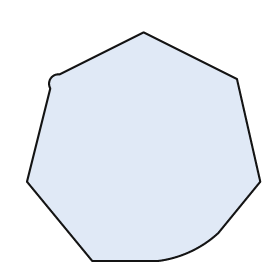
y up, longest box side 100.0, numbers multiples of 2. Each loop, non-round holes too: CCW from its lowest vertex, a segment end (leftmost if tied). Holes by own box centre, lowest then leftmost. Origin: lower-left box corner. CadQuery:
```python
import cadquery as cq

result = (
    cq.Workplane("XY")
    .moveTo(28.0, 0.0)
    .lineTo(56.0, 0.0)
    .threePointArc((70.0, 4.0), (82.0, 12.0))
    .lineTo(100.0, 34.0)
    .lineTo(90.0, 78.0)
    .lineTo(50.0, 98.0)
    .lineTo(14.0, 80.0)
    .threePointArc((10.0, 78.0), (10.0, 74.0))
    .lineTo(0.0, 34.0)
    .close()
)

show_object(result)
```